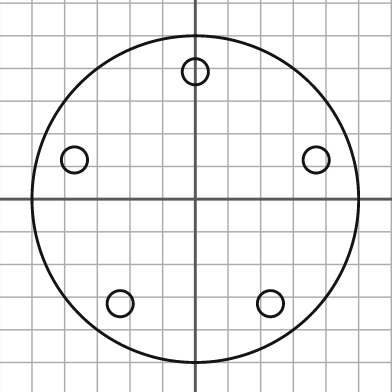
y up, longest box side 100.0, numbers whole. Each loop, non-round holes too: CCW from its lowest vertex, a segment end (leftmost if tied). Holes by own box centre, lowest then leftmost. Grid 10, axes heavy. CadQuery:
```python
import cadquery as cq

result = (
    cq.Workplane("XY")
    .moveTo(0.0, 0.0)
    .circle(50.0)
    .moveTo(-23.0, -32.0)
    .circle(4.0)
    .moveTo(23.0, -32.0)
    .circle(4.0)
    .moveTo(-37.0, 12.0)
    .circle(4.0)
    .moveTo(37.0, 12.0)
    .circle(4.0)
    .moveTo(0.0, 39.0)
    .circle(4.0)
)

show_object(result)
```